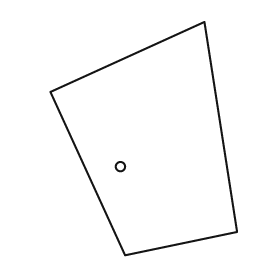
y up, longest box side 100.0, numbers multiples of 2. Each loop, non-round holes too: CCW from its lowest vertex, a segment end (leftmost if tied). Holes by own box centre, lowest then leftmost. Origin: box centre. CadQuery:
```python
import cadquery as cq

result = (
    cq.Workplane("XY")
    .moveTo(-8.0, -50.0)
    .lineTo(40.0, -40.0)
    .lineTo(26.0, 50.0)
    .lineTo(-40.0, 20.0)
    .close()
    .moveTo(-10.0, -12.0)
    .circle(2.0)
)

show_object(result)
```